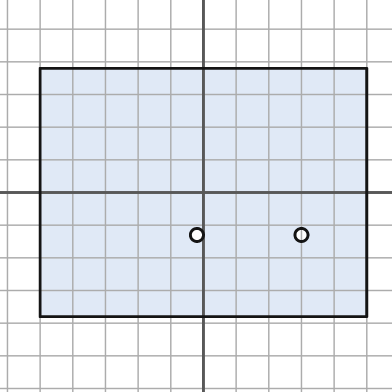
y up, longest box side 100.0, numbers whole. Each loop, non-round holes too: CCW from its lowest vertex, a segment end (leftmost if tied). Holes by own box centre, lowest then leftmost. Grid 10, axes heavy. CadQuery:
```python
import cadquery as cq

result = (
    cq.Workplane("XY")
    .moveTo(-50.0, -38.0)
    .lineTo(50.0, -38.0)
    .lineTo(50.0, 38.0)
    .lineTo(-50.0, 38.0)
    .close()
    .moveTo(-2.0, -13.0)
    .circle(2.0)
    .moveTo(30.0, -13.0)
    .circle(2.0)
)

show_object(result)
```